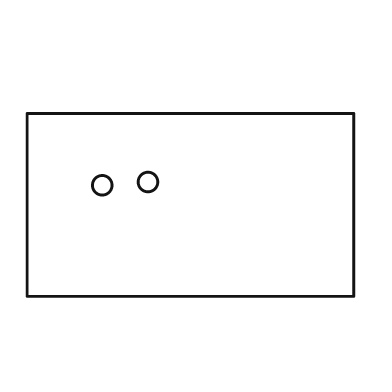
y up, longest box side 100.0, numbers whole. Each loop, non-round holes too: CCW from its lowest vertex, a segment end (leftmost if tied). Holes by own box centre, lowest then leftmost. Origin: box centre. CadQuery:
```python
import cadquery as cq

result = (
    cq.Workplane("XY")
    .moveTo(-50.0, -28.0)
    .lineTo(50.0, -28.0)
    .lineTo(50.0, 28.0)
    .lineTo(-50.0, 28.0)
    .close()
    .moveTo(-27.0, 6.0)
    .circle(3.0)
    .moveTo(-13.0, 7.0)
    .circle(3.0)
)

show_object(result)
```